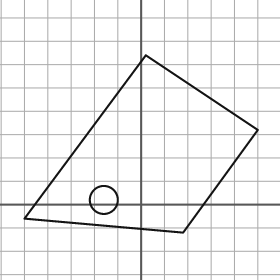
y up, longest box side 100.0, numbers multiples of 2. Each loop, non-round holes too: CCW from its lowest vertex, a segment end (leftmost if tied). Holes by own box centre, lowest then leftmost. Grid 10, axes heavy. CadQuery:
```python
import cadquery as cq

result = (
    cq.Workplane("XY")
    .moveTo(18.0, -12.0)
    .lineTo(50.0, 32.0)
    .lineTo(2.0, 64.0)
    .lineTo(-50.0, -6.0)
    .close()
    .moveTo(-16.0, 2.0)
    .circle(6.0)
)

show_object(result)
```